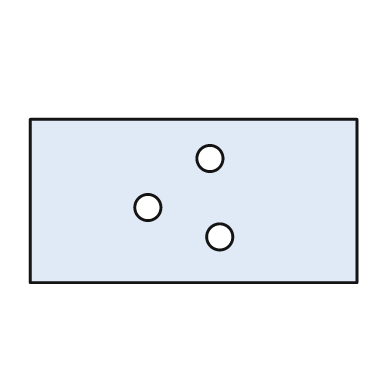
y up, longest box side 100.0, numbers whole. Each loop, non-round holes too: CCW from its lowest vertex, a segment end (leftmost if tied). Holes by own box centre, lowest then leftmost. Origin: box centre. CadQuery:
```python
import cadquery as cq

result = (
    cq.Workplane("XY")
    .moveTo(-50.0, -25.0)
    .lineTo(50.0, -25.0)
    .lineTo(50.0, 25.0)
    .lineTo(-50.0, 25.0)
    .close()
    .moveTo(8.0, -11.0)
    .circle(4.0)
    .moveTo(-14.0, -2.0)
    .circle(4.0)
    .moveTo(5.0, 13.0)
    .circle(4.0)
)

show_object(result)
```